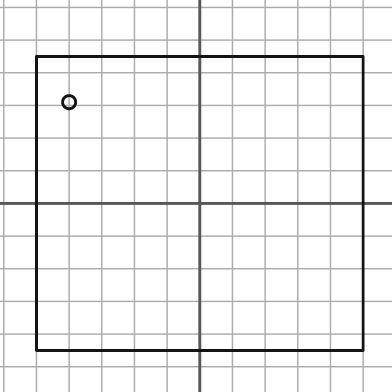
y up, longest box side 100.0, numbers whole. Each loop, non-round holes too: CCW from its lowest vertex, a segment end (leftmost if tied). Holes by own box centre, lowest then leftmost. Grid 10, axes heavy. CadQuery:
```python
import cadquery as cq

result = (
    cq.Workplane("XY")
    .moveTo(-50.0, -45.0)
    .lineTo(50.0, -45.0)
    .lineTo(50.0, 45.0)
    .lineTo(-50.0, 45.0)
    .close()
    .moveTo(-40.0, 31.0)
    .circle(2.0)
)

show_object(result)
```